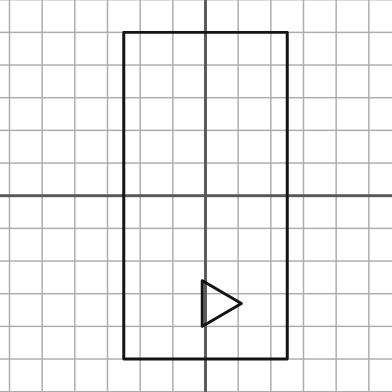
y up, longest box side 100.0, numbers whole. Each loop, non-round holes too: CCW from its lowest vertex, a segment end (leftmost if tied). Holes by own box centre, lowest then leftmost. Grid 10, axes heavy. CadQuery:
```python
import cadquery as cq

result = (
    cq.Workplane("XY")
    .moveTo(-25.0, -50.0)
    .lineTo(25.0, -50.0)
    .lineTo(25.0, 50.0)
    .lineTo(-25.0, 50.0)
    .close()
    .moveTo(-1.0, -40.0)
    .lineTo(11.0, -33.0)
    .lineTo(-1.0, -26.0)
    .close()
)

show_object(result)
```